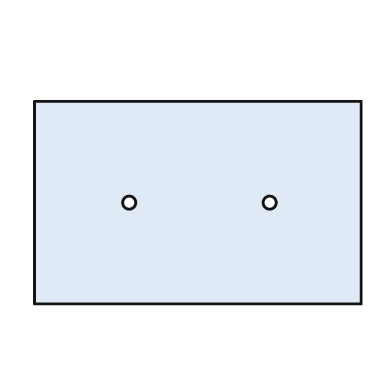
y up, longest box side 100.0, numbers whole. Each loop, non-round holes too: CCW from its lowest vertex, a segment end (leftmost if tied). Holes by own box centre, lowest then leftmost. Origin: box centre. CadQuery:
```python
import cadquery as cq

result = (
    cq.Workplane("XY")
    .moveTo(-50.0, -31.0)
    .lineTo(50.0, -31.0)
    .lineTo(50.0, 31.0)
    .lineTo(-50.0, 31.0)
    .close()
    .moveTo(-21.0, 0.0)
    .circle(2.0)
    .moveTo(22.0, 0.0)
    .circle(2.0)
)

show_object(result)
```